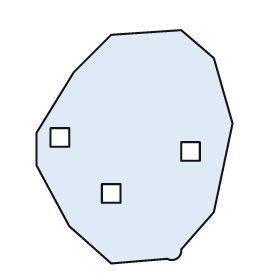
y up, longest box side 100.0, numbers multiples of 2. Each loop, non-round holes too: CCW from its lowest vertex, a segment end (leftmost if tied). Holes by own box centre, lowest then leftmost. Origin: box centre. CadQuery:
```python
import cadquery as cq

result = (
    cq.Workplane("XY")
    .moveTo(-10.0, -50.0)
    .lineTo(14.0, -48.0)
    .threePointArc((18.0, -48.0), (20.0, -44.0))
    .lineTo(34.0, -28.0)
    .lineTo(42.0, 10.0)
    .lineTo(34.0, 38.0)
    .lineTo(20.0, 50.0)
    .lineTo(-10.0, 48.0)
    .lineTo(-26.0, 32.0)
    .lineTo(-42.0, 6.0)
    .lineTo(-42.0, -8.0)
    .lineTo(-28.0, -34.0)
    .close()
    .moveTo(-14.0, -24.0)
    .lineTo(-6.0, -24.0)
    .lineTo(-6.0, -16.0)
    .lineTo(-14.0, -16.0)
    .close()
    .moveTo(20.0, -6.0)
    .lineTo(28.0, -6.0)
    .lineTo(28.0, 2.0)
    .lineTo(20.0, 2.0)
    .close()
    .moveTo(-36.0, 0.0)
    .lineTo(-28.0, 0.0)
    .lineTo(-28.0, 8.0)
    .lineTo(-36.0, 8.0)
    .close()
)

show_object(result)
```